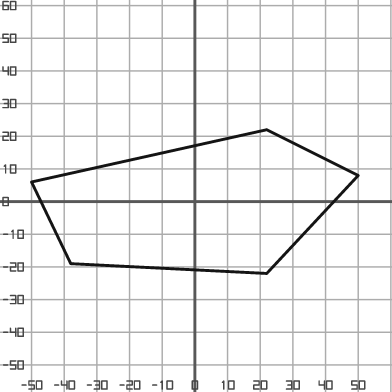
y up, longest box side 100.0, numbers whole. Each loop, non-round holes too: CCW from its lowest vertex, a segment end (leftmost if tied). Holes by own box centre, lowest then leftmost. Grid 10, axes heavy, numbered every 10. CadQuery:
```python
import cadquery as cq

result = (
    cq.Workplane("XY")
    .moveTo(22.0, -22.0)
    .lineTo(50.0, 8.0)
    .lineTo(22.0, 22.0)
    .lineTo(-50.0, 6.0)
    .lineTo(-38.0, -19.0)
    .close()
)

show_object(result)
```